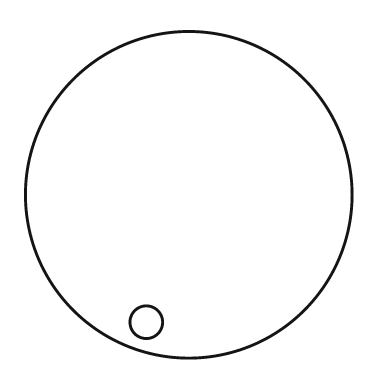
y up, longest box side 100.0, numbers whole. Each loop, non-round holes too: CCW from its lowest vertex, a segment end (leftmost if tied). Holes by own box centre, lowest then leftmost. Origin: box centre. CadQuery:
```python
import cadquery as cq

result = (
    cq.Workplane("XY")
    .moveTo(0.0, 0.0)
    .circle(50.0)
    .moveTo(-13.0, -39.0)
    .circle(5.0)
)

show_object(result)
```